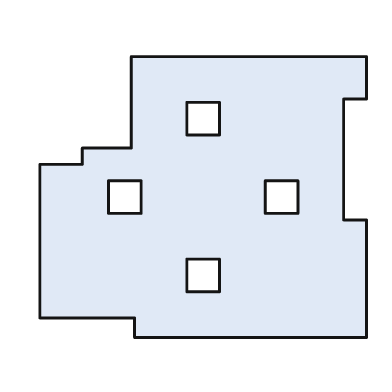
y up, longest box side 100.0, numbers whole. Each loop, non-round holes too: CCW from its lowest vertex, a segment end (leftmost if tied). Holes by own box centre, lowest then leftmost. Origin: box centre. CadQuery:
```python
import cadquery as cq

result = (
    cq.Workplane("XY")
    .moveTo(-21.0, -43.0)
    .lineTo(50.0, -43.0)
    .lineTo(50.0, -7.0)
    .lineTo(43.0, -7.0)
    .lineTo(43.0, 30.0)
    .lineTo(50.0, 30.0)
    .lineTo(50.0, 43.0)
    .lineTo(-22.0, 43.0)
    .lineTo(-22.0, 15.0)
    .lineTo(-37.0, 15.0)
    .lineTo(-37.0, 10.0)
    .lineTo(-50.0, 10.0)
    .lineTo(-50.0, -37.0)
    .lineTo(-21.0, -37.0)
    .close()
    .moveTo(-5.0, -29.0)
    .lineTo(5.0, -29.0)
    .lineTo(5.0, -19.0)
    .lineTo(-5.0, -19.0)
    .close()
    .moveTo(-29.0, -5.0)
    .lineTo(-19.0, -5.0)
    .lineTo(-19.0, 5.0)
    .lineTo(-29.0, 5.0)
    .close()
    .moveTo(19.0, -5.0)
    .lineTo(29.0, -5.0)
    .lineTo(29.0, 5.0)
    .lineTo(19.0, 5.0)
    .close()
    .moveTo(-5.0, 19.0)
    .lineTo(5.0, 19.0)
    .lineTo(5.0, 29.0)
    .lineTo(-5.0, 29.0)
    .close()
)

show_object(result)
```